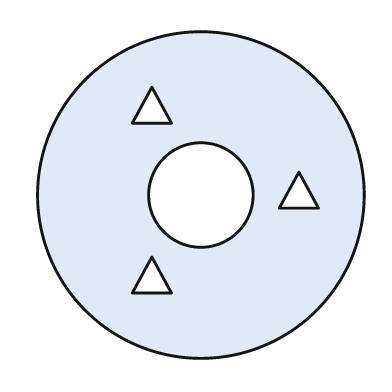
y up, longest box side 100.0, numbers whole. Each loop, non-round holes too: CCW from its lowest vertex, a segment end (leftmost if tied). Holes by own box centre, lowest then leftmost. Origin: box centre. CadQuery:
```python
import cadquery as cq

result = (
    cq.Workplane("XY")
    .moveTo(0.0, 0.0)
    .circle(50.0)
    .moveTo(-21.0, -30.0)
    .lineTo(-9.0, -30.0)
    .lineTo(-15.0, -19.0)
    .close()
    .moveTo(0.0, 0.0)
    .circle(16.0)
    .moveTo(24.0, -4.0)
    .lineTo(36.0, -4.0)
    .lineTo(30.0, 7.0)
    .close()
    .moveTo(-21.0, 22.0)
    .lineTo(-9.0, 22.0)
    .lineTo(-15.0, 33.0)
    .close()
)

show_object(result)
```